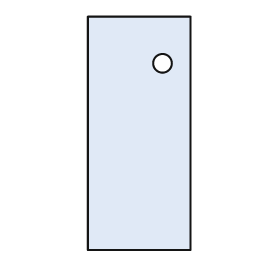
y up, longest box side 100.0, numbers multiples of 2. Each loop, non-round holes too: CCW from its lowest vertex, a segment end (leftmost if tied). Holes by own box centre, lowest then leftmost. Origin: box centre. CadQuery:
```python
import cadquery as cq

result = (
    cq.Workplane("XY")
    .moveTo(-22.0, -50.0)
    .lineTo(22.0, -50.0)
    .lineTo(22.0, 50.0)
    .lineTo(-22.0, 50.0)
    .close()
    .moveTo(10.0, 30.0)
    .circle(4.0)
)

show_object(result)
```